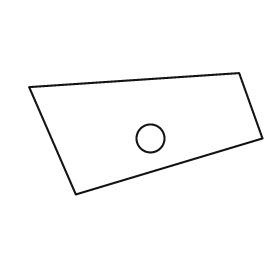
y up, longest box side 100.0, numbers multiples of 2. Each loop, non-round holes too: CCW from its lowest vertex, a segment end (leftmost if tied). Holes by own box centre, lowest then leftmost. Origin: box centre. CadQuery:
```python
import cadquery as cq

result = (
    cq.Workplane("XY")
    .moveTo(-30.0, -26.0)
    .lineTo(50.0, -2.0)
    .lineTo(40.0, 26.0)
    .lineTo(-50.0, 20.0)
    .close()
    .moveTo(2.0, -2.0)
    .circle(6.0)
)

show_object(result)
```